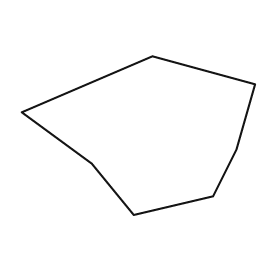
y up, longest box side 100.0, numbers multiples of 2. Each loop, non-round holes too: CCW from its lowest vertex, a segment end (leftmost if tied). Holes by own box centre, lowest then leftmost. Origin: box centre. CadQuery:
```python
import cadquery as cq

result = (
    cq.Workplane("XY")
    .moveTo(-2.0, -34.0)
    .lineTo(32.0, -26.0)
    .lineTo(42.0, -6.0)
    .lineTo(50.0, 22.0)
    .lineTo(6.0, 34.0)
    .lineTo(-50.0, 10.0)
    .lineTo(-20.0, -12.0)
    .close()
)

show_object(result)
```